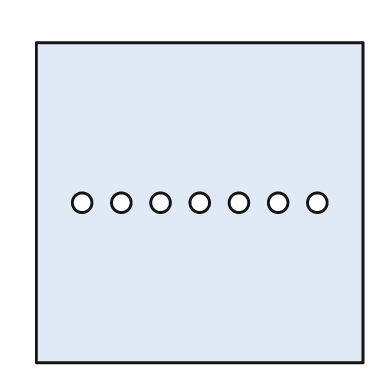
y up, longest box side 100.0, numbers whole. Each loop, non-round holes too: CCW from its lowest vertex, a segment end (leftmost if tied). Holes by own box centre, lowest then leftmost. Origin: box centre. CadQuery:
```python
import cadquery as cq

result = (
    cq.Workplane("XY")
    .moveTo(-50.0, -49.0)
    .lineTo(50.0, -49.0)
    .lineTo(50.0, 49.0)
    .lineTo(-50.0, 49.0)
    .close()
    .moveTo(-36.0, 0.0)
    .circle(3.0)
    .moveTo(-24.0, 0.0)
    .circle(3.0)
    .moveTo(-12.0, 0.0)
    .circle(3.0)
    .moveTo(0.0, 0.0)
    .circle(3.0)
    .moveTo(12.0, 0.0)
    .circle(3.0)
    .moveTo(24.0, 0.0)
    .circle(3.0)
    .moveTo(36.0, 0.0)
    .circle(3.0)
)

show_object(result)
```